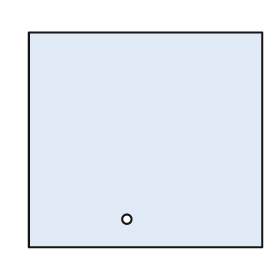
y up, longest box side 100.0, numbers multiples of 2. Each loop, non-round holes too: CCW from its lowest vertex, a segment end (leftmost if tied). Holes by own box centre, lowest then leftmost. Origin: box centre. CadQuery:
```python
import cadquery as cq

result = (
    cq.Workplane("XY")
    .moveTo(-50.0, -46.0)
    .lineTo(50.0, -46.0)
    .lineTo(50.0, 46.0)
    .lineTo(-50.0, 46.0)
    .close()
    .moveTo(-8.0, -34.0)
    .circle(2.0)
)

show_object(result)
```